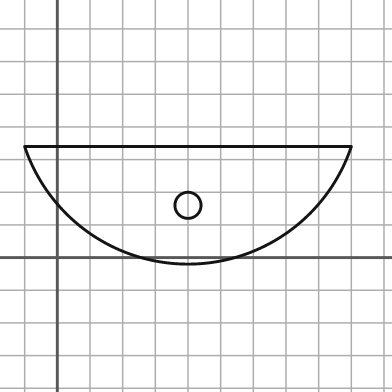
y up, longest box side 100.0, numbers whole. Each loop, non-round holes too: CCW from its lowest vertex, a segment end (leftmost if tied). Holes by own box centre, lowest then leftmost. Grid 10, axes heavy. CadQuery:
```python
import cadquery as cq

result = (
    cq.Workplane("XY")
    .moveTo(-10.0, 34.0)
    .threePointArc((40.0, -2.0), (90.0, 34.0))
    .close()
    .moveTo(40.0, 16.0)
    .circle(4.0)
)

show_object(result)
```